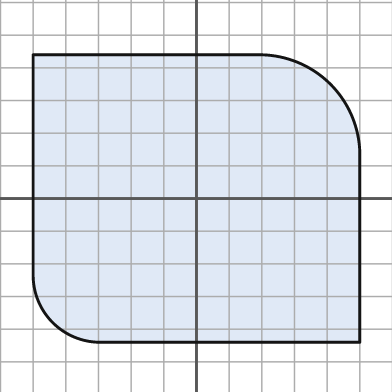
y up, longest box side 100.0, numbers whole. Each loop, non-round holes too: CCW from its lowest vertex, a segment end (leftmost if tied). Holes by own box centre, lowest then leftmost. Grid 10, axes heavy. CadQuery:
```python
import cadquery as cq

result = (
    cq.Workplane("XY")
    .moveTo(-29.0, -44.0)
    .lineTo(50.0, -44.0)
    .lineTo(50.0, 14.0)
    .threePointArc((41.0, 35.0), (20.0, 44.0))
    .lineTo(-50.0, 44.0)
    .lineTo(-50.0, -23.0)
    .threePointArc((-44.0, -38.0), (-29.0, -44.0))
    .close()
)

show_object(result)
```